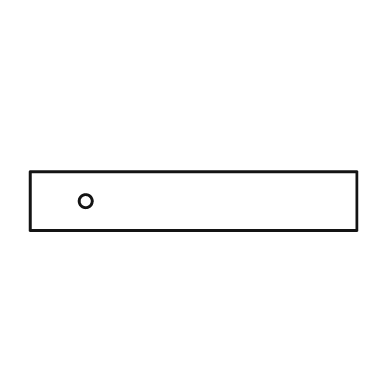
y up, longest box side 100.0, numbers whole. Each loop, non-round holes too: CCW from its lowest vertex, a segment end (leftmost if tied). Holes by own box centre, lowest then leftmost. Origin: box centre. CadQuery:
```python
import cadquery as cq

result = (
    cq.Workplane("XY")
    .moveTo(-50.0, -9.0)
    .lineTo(50.0, -9.0)
    .lineTo(50.0, 9.0)
    .lineTo(-50.0, 9.0)
    .close()
    .moveTo(-33.0, 0.0)
    .circle(2.0)
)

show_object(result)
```